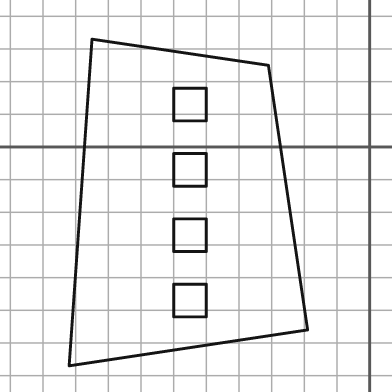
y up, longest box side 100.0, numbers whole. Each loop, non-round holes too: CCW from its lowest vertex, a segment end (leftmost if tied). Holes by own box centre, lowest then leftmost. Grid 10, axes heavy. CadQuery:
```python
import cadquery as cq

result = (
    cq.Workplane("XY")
    .moveTo(-92.0, -67.0)
    .lineTo(-19.0, -56.0)
    .lineTo(-31.0, 25.0)
    .lineTo(-85.0, 33.0)
    .close()
    .moveTo(-60.0, -52.0)
    .lineTo(-50.0, -52.0)
    .lineTo(-50.0, -42.0)
    .lineTo(-60.0, -42.0)
    .close()
    .moveTo(-60.0, -32.0)
    .lineTo(-50.0, -32.0)
    .lineTo(-50.0, -22.0)
    .lineTo(-60.0, -22.0)
    .close()
    .moveTo(-60.0, -12.0)
    .lineTo(-50.0, -12.0)
    .lineTo(-50.0, -2.0)
    .lineTo(-60.0, -2.0)
    .close()
    .moveTo(-60.0, 8.0)
    .lineTo(-50.0, 8.0)
    .lineTo(-50.0, 18.0)
    .lineTo(-60.0, 18.0)
    .close()
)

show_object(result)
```